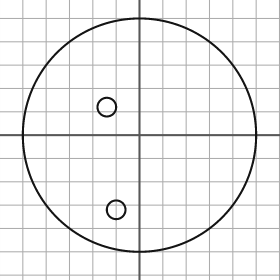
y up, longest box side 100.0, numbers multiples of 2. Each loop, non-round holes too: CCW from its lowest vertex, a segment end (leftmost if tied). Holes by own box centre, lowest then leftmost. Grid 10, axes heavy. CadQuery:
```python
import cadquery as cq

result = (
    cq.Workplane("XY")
    .moveTo(0.0, 0.0)
    .circle(50.0)
    .moveTo(-10.0, -32.0)
    .circle(4.0)
    .moveTo(-14.0, 12.0)
    .circle(4.0)
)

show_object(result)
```